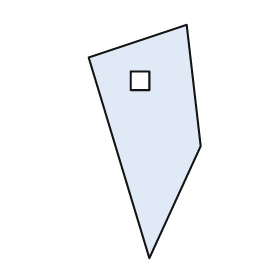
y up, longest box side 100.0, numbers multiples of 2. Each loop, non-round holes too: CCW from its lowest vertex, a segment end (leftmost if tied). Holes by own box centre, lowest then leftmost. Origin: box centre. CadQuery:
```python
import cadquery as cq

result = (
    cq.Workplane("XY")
    .moveTo(2.0, -50.0)
    .lineTo(24.0, -2.0)
    .lineTo(18.0, 50.0)
    .lineTo(-24.0, 36.0)
    .close()
    .moveTo(-6.0, 22.0)
    .lineTo(2.0, 22.0)
    .lineTo(2.0, 30.0)
    .lineTo(-6.0, 30.0)
    .close()
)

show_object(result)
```